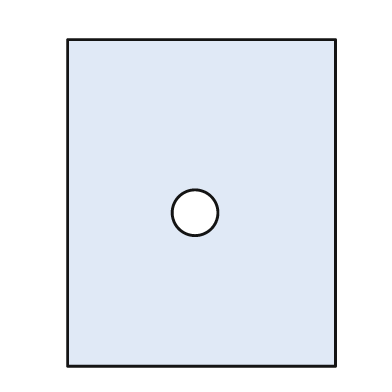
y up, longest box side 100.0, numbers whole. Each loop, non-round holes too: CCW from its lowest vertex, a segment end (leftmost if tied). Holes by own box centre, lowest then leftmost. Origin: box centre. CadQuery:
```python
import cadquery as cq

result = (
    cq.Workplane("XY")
    .moveTo(-41.0, -50.0)
    .lineTo(41.0, -50.0)
    .lineTo(41.0, 50.0)
    .lineTo(-41.0, 50.0)
    .close()
    .moveTo(-2.0, -3.0)
    .circle(7.0)
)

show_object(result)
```